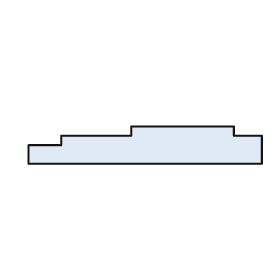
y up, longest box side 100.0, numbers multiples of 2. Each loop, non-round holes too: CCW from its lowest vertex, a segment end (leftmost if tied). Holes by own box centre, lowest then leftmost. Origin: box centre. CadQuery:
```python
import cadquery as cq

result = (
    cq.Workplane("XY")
    .moveTo(-50.0, -8.0)
    .lineTo(50.0, -8.0)
    .lineTo(50.0, 4.0)
    .lineTo(38.0, 4.0)
    .lineTo(38.0, 8.0)
    .lineTo(-6.0, 8.0)
    .lineTo(-6.0, 4.0)
    .lineTo(-36.0, 4.0)
    .lineTo(-36.0, 0.0)
    .lineTo(-50.0, 0.0)
    .close()
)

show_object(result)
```